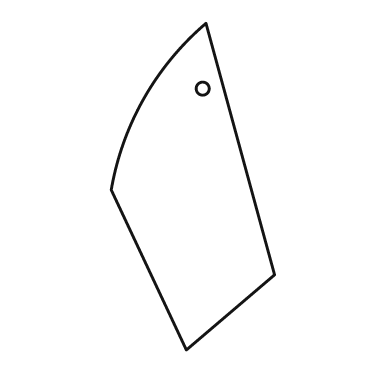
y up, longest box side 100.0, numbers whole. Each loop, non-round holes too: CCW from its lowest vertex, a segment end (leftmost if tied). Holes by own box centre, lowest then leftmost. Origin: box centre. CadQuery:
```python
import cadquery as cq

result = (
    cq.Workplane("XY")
    .moveTo(-2.0, -50.0)
    .lineTo(25.0, -27.0)
    .lineTo(4.0, 50.0)
    .threePointArc((-15.0, 27.0), (-25.0, -1.0))
    .close()
    .moveTo(3.0, 30.0)
    .circle(2.0)
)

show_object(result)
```